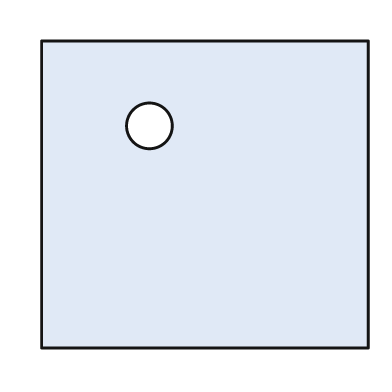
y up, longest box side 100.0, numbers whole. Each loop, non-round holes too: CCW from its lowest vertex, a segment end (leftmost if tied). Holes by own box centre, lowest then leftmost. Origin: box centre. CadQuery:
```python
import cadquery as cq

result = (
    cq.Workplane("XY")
    .moveTo(-50.0, -47.0)
    .lineTo(50.0, -47.0)
    .lineTo(50.0, 47.0)
    .lineTo(-50.0, 47.0)
    .close()
    .moveTo(-17.0, 21.0)
    .circle(7.0)
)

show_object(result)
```